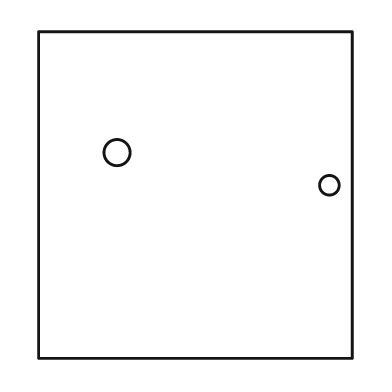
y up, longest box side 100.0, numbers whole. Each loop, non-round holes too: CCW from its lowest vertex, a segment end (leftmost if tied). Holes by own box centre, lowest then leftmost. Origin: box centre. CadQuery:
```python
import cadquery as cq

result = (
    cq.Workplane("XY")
    .moveTo(-48.0, -50.0)
    .lineTo(48.0, -50.0)
    .lineTo(48.0, 50.0)
    .lineTo(-48.0, 50.0)
    .close()
    .moveTo(41.0, 3.0)
    .circle(3.0)
    .moveTo(-24.0, 13.0)
    .circle(4.0)
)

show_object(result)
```